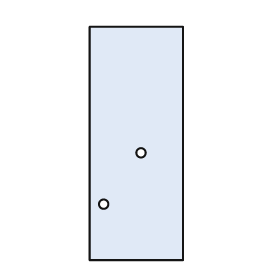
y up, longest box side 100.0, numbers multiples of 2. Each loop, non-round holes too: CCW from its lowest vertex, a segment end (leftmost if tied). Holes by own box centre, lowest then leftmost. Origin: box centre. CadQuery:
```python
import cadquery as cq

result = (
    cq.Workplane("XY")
    .moveTo(-20.0, -50.0)
    .lineTo(20.0, -50.0)
    .lineTo(20.0, 50.0)
    .lineTo(-20.0, 50.0)
    .close()
    .moveTo(-14.0, -26.0)
    .circle(2.0)
    .moveTo(2.0, -4.0)
    .circle(2.0)
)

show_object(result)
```